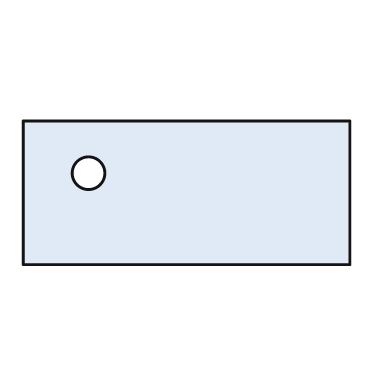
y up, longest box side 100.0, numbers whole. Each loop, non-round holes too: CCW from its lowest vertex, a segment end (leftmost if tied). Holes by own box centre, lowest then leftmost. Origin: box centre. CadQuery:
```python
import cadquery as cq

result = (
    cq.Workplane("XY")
    .moveTo(-50.0, -22.0)
    .lineTo(50.0, -22.0)
    .lineTo(50.0, 22.0)
    .lineTo(-50.0, 22.0)
    .close()
    .moveTo(-30.0, 6.0)
    .circle(5.0)
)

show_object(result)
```